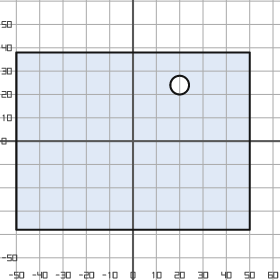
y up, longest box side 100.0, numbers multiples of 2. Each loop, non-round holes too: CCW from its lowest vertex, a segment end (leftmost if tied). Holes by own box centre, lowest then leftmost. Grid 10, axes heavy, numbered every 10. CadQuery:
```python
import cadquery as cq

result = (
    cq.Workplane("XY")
    .moveTo(-50.0, -38.0)
    .lineTo(50.0, -38.0)
    .lineTo(50.0, 38.0)
    .lineTo(-50.0, 38.0)
    .close()
    .moveTo(20.0, 24.0)
    .circle(4.0)
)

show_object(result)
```